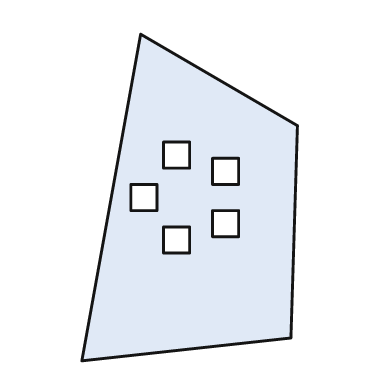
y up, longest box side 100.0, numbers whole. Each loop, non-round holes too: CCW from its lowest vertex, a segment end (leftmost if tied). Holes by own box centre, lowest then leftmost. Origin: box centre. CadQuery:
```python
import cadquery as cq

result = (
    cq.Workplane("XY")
    .moveTo(-33.0, -50.0)
    .lineTo(31.0, -43.0)
    .lineTo(33.0, 22.0)
    .lineTo(-15.0, 50.0)
    .close()
    .moveTo(-8.0, -17.0)
    .lineTo(0.0, -17.0)
    .lineTo(0.0, -9.0)
    .lineTo(-8.0, -9.0)
    .close()
    .moveTo(7.0, -12.0)
    .lineTo(15.0, -12.0)
    .lineTo(15.0, -4.0)
    .lineTo(7.0, -4.0)
    .close()
    .moveTo(-18.0, -4.0)
    .lineTo(-10.0, -4.0)
    .lineTo(-10.0, 4.0)
    .lineTo(-18.0, 4.0)
    .close()
    .moveTo(7.0, 4.0)
    .lineTo(15.0, 4.0)
    .lineTo(15.0, 12.0)
    .lineTo(7.0, 12.0)
    .close()
    .moveTo(-8.0, 9.0)
    .lineTo(0.0, 9.0)
    .lineTo(0.0, 17.0)
    .lineTo(-8.0, 17.0)
    .close()
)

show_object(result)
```